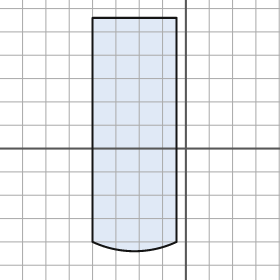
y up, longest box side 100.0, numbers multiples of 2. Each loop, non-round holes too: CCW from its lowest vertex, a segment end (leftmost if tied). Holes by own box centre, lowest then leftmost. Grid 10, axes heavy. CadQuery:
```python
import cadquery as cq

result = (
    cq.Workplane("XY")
    .moveTo(-40.0, -40.0)
    .threePointArc((-22.0, -44.0), (-4.0, -40.0))
    .lineTo(-4.0, 56.0)
    .lineTo(-40.0, 56.0)
    .close()
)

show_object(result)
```